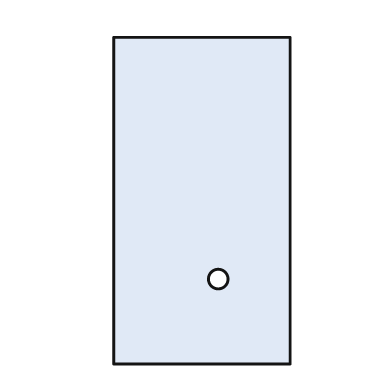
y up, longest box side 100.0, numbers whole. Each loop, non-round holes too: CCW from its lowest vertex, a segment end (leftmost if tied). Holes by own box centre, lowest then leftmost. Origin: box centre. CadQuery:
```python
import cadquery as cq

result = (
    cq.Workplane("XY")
    .moveTo(-27.0, -50.0)
    .lineTo(27.0, -50.0)
    .lineTo(27.0, 50.0)
    .lineTo(-27.0, 50.0)
    .close()
    .moveTo(5.0, -24.0)
    .circle(3.0)
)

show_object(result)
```